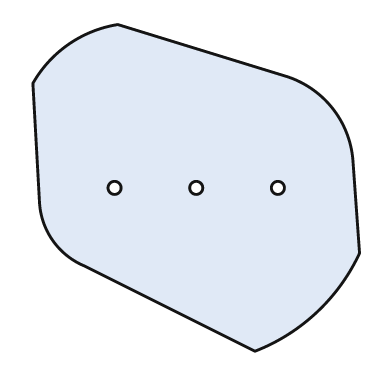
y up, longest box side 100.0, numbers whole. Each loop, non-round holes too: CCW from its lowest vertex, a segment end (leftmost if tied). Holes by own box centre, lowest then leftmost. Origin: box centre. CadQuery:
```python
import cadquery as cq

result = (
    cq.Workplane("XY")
    .moveTo(18.0, -50.0)
    .threePointArc((37.0, -38.0), (50.0, -20.0))
    .lineTo(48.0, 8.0)
    .threePointArc((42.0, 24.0), (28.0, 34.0))
    .lineTo(-24.0, 50.0)
    .threePointArc((-39.0, 44.0), (-50.0, 32.0))
    .lineTo(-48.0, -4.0)
    .threePointArc((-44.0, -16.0), (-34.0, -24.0))
    .close()
    .moveTo(-25.0, 0.0)
    .circle(2.0)
    .moveTo(0.0, 0.0)
    .circle(2.0)
    .moveTo(25.0, 0.0)
    .circle(2.0)
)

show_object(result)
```